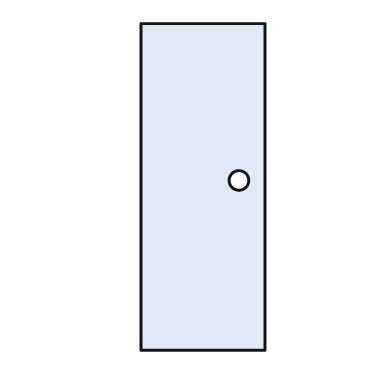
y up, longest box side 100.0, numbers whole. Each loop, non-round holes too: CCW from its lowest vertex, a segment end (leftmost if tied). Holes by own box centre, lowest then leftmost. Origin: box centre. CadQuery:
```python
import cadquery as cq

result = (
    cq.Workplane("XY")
    .moveTo(-19.0, -50.0)
    .lineTo(19.0, -50.0)
    .lineTo(19.0, 50.0)
    .lineTo(-19.0, 50.0)
    .close()
    .moveTo(11.0, 2.0)
    .circle(3.0)
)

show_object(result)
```